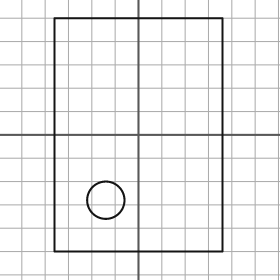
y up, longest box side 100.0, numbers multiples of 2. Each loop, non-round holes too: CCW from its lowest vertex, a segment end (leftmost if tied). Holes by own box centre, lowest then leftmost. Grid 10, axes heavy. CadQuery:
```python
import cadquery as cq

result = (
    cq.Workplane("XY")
    .moveTo(-36.0, -50.0)
    .lineTo(36.0, -50.0)
    .lineTo(36.0, 50.0)
    .lineTo(-36.0, 50.0)
    .close()
    .moveTo(-14.0, -28.0)
    .circle(8.0)
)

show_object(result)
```